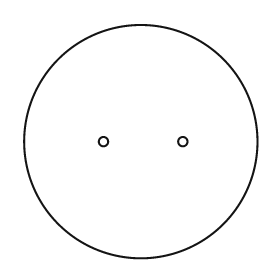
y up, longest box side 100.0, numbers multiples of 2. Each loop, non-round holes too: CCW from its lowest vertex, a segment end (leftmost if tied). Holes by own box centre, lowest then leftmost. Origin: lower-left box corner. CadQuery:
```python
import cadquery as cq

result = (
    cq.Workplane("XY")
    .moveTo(50.0, 50.0)
    .circle(50.0)
    .moveTo(34.0, 50.0)
    .circle(2.0)
    .moveTo(68.0, 50.0)
    .circle(2.0)
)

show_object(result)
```